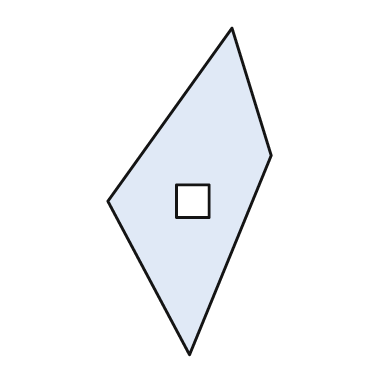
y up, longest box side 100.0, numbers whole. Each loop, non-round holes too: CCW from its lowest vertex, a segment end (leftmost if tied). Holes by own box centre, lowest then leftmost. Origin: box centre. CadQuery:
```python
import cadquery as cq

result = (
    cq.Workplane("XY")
    .moveTo(0.0, -50.0)
    .lineTo(25.0, 11.0)
    .lineTo(13.0, 50.0)
    .lineTo(-25.0, -3.0)
    .close()
    .moveTo(-4.0, -8.0)
    .lineTo(6.0, -8.0)
    .lineTo(6.0, 2.0)
    .lineTo(-4.0, 2.0)
    .close()
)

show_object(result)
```